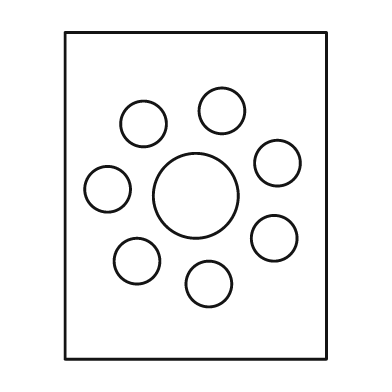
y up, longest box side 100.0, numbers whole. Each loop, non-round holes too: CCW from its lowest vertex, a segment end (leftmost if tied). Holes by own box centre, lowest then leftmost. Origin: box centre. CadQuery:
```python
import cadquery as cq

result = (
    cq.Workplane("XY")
    .moveTo(-40.0, -50.0)
    .lineTo(40.0, -50.0)
    .lineTo(40.0, 50.0)
    .lineTo(-40.0, 50.0)
    .close()
    .moveTo(4.0, -27.0)
    .circle(7.0)
    .moveTo(-18.0, -20.0)
    .circle(7.0)
    .moveTo(24.0, -13.0)
    .circle(7.0)
    .moveTo(0.0, 0.0)
    .circle(13.0)
    .moveTo(-27.0, 2.0)
    .circle(7.0)
    .moveTo(25.0, 10.0)
    .circle(7.0)
    .moveTo(-16.0, 22.0)
    .circle(7.0)
    .moveTo(8.0, 26.0)
    .circle(7.0)
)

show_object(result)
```